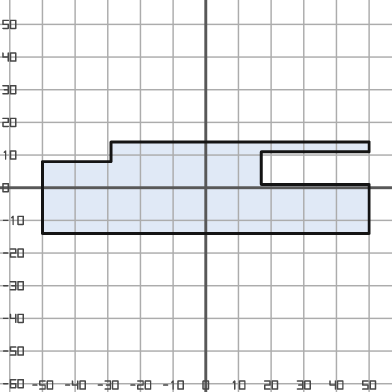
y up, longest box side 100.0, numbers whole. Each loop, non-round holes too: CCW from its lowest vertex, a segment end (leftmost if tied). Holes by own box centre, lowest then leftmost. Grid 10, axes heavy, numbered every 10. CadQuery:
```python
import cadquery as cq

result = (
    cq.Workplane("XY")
    .moveTo(-50.0, -14.0)
    .lineTo(50.0, -14.0)
    .lineTo(50.0, 1.0)
    .lineTo(17.0, 1.0)
    .lineTo(17.0, 11.0)
    .lineTo(50.0, 11.0)
    .lineTo(50.0, 14.0)
    .lineTo(-29.0, 14.0)
    .lineTo(-29.0, 8.0)
    .lineTo(-50.0, 8.0)
    .close()
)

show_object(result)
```